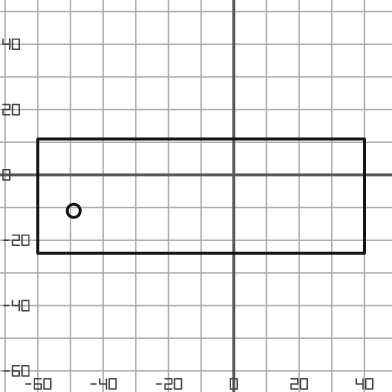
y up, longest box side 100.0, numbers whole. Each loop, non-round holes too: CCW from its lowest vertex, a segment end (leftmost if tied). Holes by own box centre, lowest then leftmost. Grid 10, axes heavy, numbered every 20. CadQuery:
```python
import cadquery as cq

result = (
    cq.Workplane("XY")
    .moveTo(-60.0, -24.0)
    .lineTo(40.0, -24.0)
    .lineTo(40.0, 11.0)
    .lineTo(-60.0, 11.0)
    .close()
    .moveTo(-49.0, -11.0)
    .circle(2.0)
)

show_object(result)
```